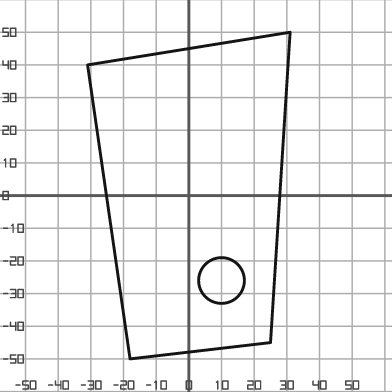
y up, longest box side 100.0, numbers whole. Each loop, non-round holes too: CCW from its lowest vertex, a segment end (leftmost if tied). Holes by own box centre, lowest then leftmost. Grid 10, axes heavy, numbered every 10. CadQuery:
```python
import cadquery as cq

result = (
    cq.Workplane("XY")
    .moveTo(-18.0, -50.0)
    .lineTo(25.0, -45.0)
    .lineTo(31.0, 50.0)
    .lineTo(-31.0, 40.0)
    .close()
    .moveTo(10.0, -26.0)
    .circle(7.0)
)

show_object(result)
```